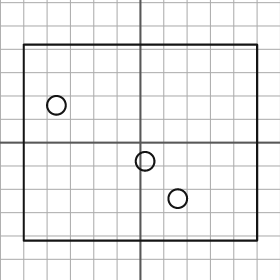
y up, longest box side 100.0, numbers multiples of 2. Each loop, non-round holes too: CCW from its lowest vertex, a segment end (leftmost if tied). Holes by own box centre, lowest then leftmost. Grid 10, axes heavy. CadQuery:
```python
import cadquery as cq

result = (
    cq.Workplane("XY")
    .moveTo(-50.0, -42.0)
    .lineTo(50.0, -42.0)
    .lineTo(50.0, 42.0)
    .lineTo(-50.0, 42.0)
    .close()
    .moveTo(16.0, -24.0)
    .circle(4.0)
    .moveTo(2.0, -8.0)
    .circle(4.0)
    .moveTo(-36.0, 16.0)
    .circle(4.0)
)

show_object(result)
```